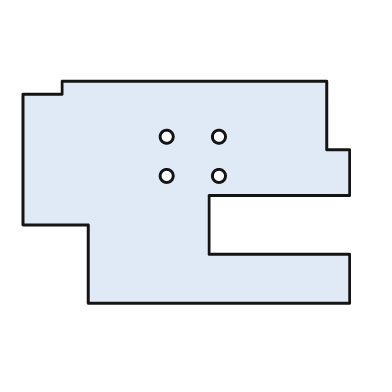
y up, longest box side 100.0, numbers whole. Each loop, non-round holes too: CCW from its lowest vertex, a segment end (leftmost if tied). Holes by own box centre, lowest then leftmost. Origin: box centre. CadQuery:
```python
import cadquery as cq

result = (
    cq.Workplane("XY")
    .moveTo(-30.0, -34.0)
    .lineTo(50.0, -34.0)
    .lineTo(50.0, -19.0)
    .lineTo(7.0, -19.0)
    .lineTo(7.0, -1.0)
    .lineTo(50.0, -1.0)
    .lineTo(50.0, 13.0)
    .lineTo(43.0, 13.0)
    .lineTo(43.0, 34.0)
    .lineTo(-38.0, 34.0)
    .lineTo(-38.0, 30.0)
    .lineTo(-50.0, 30.0)
    .lineTo(-50.0, -10.0)
    .lineTo(-30.0, -10.0)
    .close()
    .moveTo(-6.0, 5.0)
    .circle(2.0)
    .moveTo(10.0, 5.0)
    .circle(2.0)
    .moveTo(-6.0, 17.0)
    .circle(2.0)
    .moveTo(10.0, 17.0)
    .circle(2.0)
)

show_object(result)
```